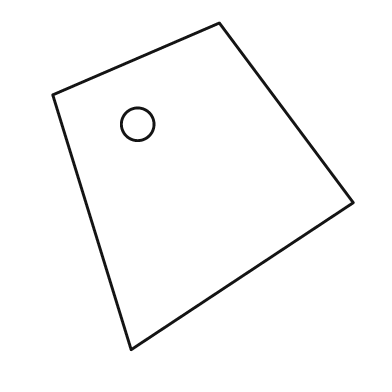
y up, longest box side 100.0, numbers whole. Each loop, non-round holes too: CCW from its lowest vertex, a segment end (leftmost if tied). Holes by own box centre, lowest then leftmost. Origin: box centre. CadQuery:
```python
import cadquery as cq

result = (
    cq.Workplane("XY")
    .moveTo(-22.0, -50.0)
    .lineTo(46.0, -5.0)
    .lineTo(5.0, 50.0)
    .lineTo(-46.0, 28.0)
    .close()
    .moveTo(-20.0, 19.0)
    .circle(5.0)
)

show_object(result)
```